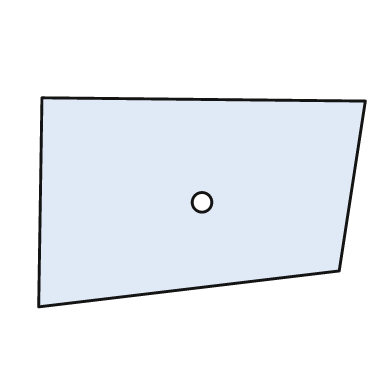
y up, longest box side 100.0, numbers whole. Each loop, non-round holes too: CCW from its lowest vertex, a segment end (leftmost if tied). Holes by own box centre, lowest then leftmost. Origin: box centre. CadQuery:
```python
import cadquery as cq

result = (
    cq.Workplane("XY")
    .moveTo(-50.0, -32.0)
    .lineTo(42.0, -21.0)
    .lineTo(50.0, 31.0)
    .lineTo(-49.0, 32.0)
    .close()
    .moveTo(0.0, 0.0)
    .circle(3.0)
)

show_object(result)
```